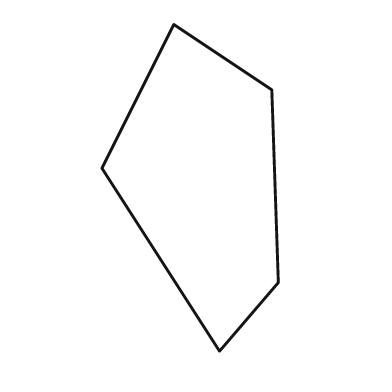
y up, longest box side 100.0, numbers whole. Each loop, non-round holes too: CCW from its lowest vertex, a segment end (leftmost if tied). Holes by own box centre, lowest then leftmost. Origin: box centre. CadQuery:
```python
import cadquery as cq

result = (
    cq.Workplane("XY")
    .moveTo(9.0, -50.0)
    .lineTo(27.0, -29.0)
    .lineTo(25.0, 30.0)
    .lineTo(-5.0, 50.0)
    .lineTo(-27.0, 6.0)
    .close()
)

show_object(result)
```